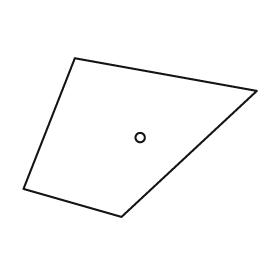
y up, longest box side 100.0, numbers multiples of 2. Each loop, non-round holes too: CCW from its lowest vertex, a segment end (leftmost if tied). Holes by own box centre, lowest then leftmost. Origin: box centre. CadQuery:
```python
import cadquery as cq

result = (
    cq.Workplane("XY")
    .moveTo(-8.0, -34.0)
    .lineTo(50.0, 20.0)
    .lineTo(-28.0, 34.0)
    .lineTo(-50.0, -22.0)
    .close()
    .moveTo(0.0, 0.0)
    .circle(2.0)
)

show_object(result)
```